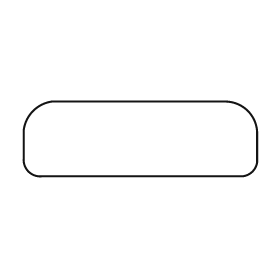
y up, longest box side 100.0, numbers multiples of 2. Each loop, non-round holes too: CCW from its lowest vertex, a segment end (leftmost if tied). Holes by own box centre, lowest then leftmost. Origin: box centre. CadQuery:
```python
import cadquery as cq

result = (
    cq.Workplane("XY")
    .moveTo(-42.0, -16.0)
    .lineTo(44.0, -16.0)
    .threePointArc((48.0, -14.0), (50.0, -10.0))
    .lineTo(50.0, 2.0)
    .threePointArc((46.0, 12.0), (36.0, 16.0))
    .lineTo(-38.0, 16.0)
    .threePointArc((-46.0, 12.0), (-50.0, 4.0))
    .lineTo(-50.0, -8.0)
    .threePointArc((-48.0, -14.0), (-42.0, -16.0))
    .close()
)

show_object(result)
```